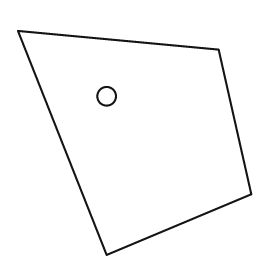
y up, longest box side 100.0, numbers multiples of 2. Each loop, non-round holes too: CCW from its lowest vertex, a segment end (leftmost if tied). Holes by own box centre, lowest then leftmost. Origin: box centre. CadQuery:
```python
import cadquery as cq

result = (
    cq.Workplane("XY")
    .moveTo(-12.0, -48.0)
    .lineTo(50.0, -22.0)
    .lineTo(36.0, 40.0)
    .lineTo(-50.0, 48.0)
    .close()
    .moveTo(-12.0, 20.0)
    .circle(4.0)
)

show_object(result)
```